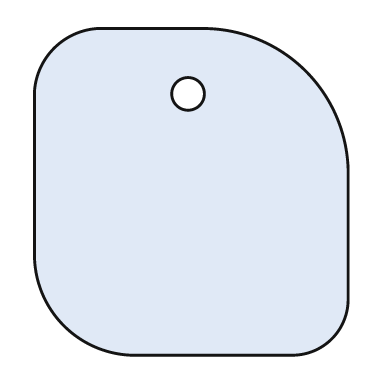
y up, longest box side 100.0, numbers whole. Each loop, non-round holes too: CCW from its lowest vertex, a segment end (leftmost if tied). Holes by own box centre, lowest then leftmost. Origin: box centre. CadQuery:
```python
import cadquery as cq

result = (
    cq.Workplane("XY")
    .moveTo(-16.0, -50.0)
    .lineTo(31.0, -50.0)
    .threePointArc((43.0, -45.0), (48.0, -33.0))
    .lineTo(48.0, 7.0)
    .threePointArc((35.0, 37.0), (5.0, 50.0))
    .lineTo(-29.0, 50.0)
    .threePointArc((-42.0, 44.0), (-48.0, 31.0))
    .lineTo(-48.0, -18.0)
    .threePointArc((-39.0, -41.0), (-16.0, -50.0))
    .close()
    .moveTo(-1.0, 30.0)
    .circle(5.0)
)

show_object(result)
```